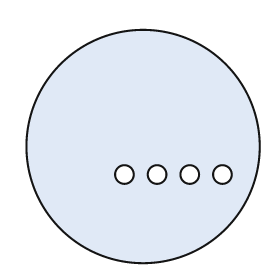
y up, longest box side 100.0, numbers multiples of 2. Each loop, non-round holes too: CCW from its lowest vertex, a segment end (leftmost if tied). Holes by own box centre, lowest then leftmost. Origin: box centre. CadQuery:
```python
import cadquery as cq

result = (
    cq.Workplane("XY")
    .moveTo(0.0, 0.0)
    .circle(50.0)
    .moveTo(-8.0, -12.0)
    .circle(4.0)
    .moveTo(6.0, -12.0)
    .circle(4.0)
    .moveTo(20.0, -12.0)
    .circle(4.0)
    .moveTo(34.0, -12.0)
    .circle(4.0)
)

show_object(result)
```